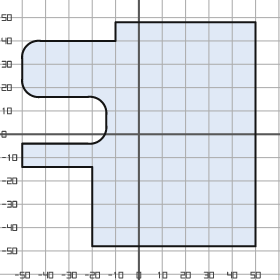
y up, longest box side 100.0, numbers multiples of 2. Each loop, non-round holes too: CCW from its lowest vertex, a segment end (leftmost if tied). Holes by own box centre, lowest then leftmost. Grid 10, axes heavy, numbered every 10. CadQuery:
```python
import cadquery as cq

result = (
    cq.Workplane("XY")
    .moveTo(-20.0, -48.0)
    .lineTo(50.0, -48.0)
    .lineTo(50.0, 48.0)
    .lineTo(-10.0, 48.0)
    .lineTo(-10.0, 40.0)
    .lineTo(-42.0, 40.0)
    .threePointArc((-48.0, 38.0), (-50.0, 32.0))
    .lineTo(-50.0, 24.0)
    .threePointArc((-48.0, 18.0), (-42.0, 16.0))
    .lineTo(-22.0, 16.0)
    .threePointArc((-16.0, 14.0), (-14.0, 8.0))
    .lineTo(-14.0, 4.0)
    .threePointArc((-16.0, -2.0), (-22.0, -4.0))
    .lineTo(-50.0, -4.0)
    .lineTo(-50.0, -14.0)
    .lineTo(-20.0, -14.0)
    .close()
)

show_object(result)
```